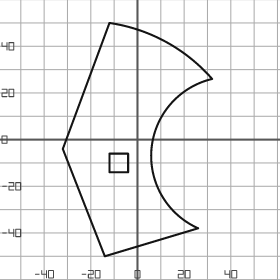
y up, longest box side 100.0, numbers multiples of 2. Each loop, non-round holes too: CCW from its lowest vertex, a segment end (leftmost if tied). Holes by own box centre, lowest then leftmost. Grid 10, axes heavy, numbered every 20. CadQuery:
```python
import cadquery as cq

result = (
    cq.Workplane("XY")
    .moveTo(-14.0, -50.0)
    .lineTo(26.0, -38.0)
    .threePointArc((6.0, -4.0), (32.0, 26.0))
    .threePointArc((12.0, 42.0), (-12.0, 50.0))
    .lineTo(-32.0, -4.0)
    .close()
    .moveTo(-12.0, -14.0)
    .lineTo(-4.0, -14.0)
    .lineTo(-4.0, -6.0)
    .lineTo(-12.0, -6.0)
    .close()
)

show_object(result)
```